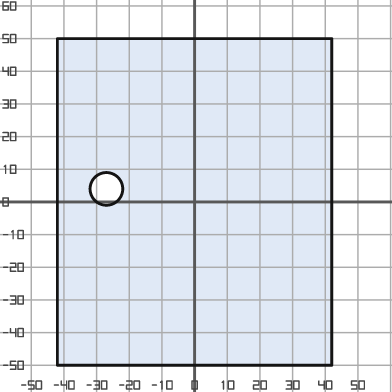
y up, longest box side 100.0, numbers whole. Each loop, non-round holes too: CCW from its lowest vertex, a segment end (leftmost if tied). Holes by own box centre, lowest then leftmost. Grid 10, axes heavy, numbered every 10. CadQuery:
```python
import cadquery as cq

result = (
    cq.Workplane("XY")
    .moveTo(-42.0, -50.0)
    .lineTo(42.0, -50.0)
    .lineTo(42.0, 50.0)
    .lineTo(-42.0, 50.0)
    .close()
    .moveTo(-27.0, 4.0)
    .circle(5.0)
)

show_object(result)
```